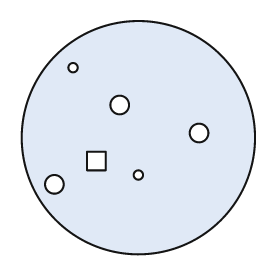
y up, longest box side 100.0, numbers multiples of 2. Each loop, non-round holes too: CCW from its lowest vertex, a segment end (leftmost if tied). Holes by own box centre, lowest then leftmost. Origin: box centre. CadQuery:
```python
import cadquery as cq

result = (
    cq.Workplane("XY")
    .moveTo(0.0, 0.0)
    .circle(50.0)
    .moveTo(-36.0, -20.0)
    .circle(4.0)
    .moveTo(0.0, -16.0)
    .circle(2.0)
    .moveTo(-22.0, -14.0)
    .lineTo(-14.0, -14.0)
    .lineTo(-14.0, -6.0)
    .lineTo(-22.0, -6.0)
    .close()
    .moveTo(26.0, 2.0)
    .circle(4.0)
    .moveTo(-8.0, 14.0)
    .circle(4.0)
    .moveTo(-28.0, 30.0)
    .circle(2.0)
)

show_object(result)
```